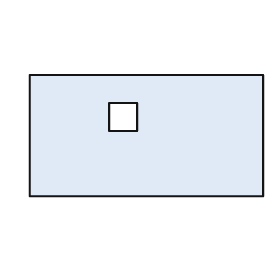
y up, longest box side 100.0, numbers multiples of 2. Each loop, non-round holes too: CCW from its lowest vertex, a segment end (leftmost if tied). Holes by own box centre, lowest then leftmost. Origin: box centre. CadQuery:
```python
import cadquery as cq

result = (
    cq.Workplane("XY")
    .moveTo(-50.0, -26.0)
    .lineTo(50.0, -26.0)
    .lineTo(50.0, 26.0)
    .lineTo(-50.0, 26.0)
    .close()
    .moveTo(-16.0, 2.0)
    .lineTo(-4.0, 2.0)
    .lineTo(-4.0, 14.0)
    .lineTo(-16.0, 14.0)
    .close()
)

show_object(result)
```